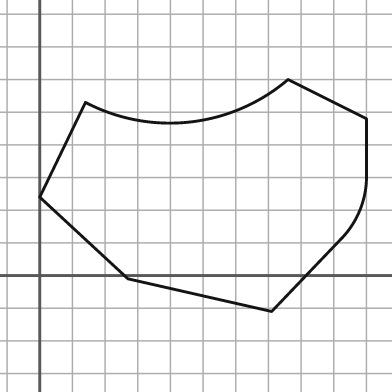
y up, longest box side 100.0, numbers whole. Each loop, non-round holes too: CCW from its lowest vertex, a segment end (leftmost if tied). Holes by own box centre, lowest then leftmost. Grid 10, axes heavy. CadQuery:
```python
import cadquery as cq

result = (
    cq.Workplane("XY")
    .moveTo(71.0, -11.0)
    .lineTo(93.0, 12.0)
    .threePointArc((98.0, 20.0), (100.0, 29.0))
    .lineTo(100.0, 48.0)
    .lineTo(76.0, 60.0)
    .threePointArc((46.0, 47.0), (14.0, 53.0))
    .lineTo(0.0, 24.0)
    .lineTo(27.0, -1.0)
    .close()
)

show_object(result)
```